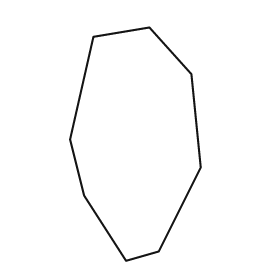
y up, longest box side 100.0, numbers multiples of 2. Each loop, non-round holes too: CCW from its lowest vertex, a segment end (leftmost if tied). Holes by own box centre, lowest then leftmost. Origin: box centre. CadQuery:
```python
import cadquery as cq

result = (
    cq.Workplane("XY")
    .moveTo(-4.0, -50.0)
    .lineTo(10.0, -46.0)
    .lineTo(28.0, -10.0)
    .lineTo(24.0, 30.0)
    .lineTo(6.0, 50.0)
    .lineTo(-18.0, 46.0)
    .lineTo(-28.0, 2.0)
    .lineTo(-22.0, -22.0)
    .close()
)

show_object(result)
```